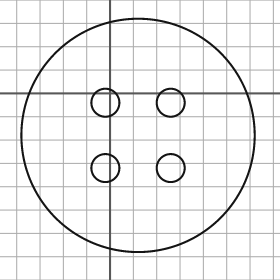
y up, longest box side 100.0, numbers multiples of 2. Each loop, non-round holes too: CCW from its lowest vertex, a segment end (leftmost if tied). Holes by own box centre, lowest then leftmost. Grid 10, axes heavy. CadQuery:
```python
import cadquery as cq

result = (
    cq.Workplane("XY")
    .moveTo(12.0, -18.0)
    .circle(50.0)
    .moveTo(-2.0, -32.0)
    .circle(6.0)
    .moveTo(26.0, -32.0)
    .circle(6.0)
    .moveTo(-2.0, -4.0)
    .circle(6.0)
    .moveTo(26.0, -4.0)
    .circle(6.0)
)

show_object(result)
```